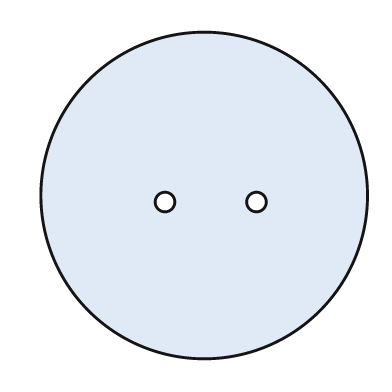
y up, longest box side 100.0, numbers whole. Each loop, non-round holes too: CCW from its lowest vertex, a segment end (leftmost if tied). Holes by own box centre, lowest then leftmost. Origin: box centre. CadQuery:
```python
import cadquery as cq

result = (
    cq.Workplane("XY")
    .moveTo(0.0, 0.0)
    .circle(50.0)
    .moveTo(-12.0, -2.0)
    .circle(3.0)
    .moveTo(16.0, -2.0)
    .circle(3.0)
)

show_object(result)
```